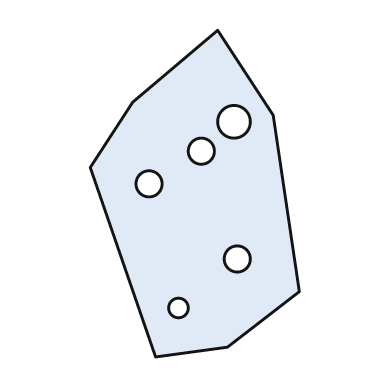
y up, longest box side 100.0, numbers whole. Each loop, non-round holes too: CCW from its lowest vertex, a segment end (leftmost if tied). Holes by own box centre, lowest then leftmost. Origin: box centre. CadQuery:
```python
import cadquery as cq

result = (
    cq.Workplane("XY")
    .moveTo(-12.0, -50.0)
    .lineTo(10.0, -47.0)
    .lineTo(32.0, -30.0)
    .lineTo(24.0, 24.0)
    .lineTo(7.0, 50.0)
    .lineTo(-19.0, 28.0)
    .lineTo(-32.0, 8.0)
    .close()
    .moveTo(-5.0, -35.0)
    .circle(3.0)
    .moveTo(13.0, -20.0)
    .circle(4.0)
    .moveTo(-14.0, 3.0)
    .circle(4.0)
    .moveTo(2.0, 13.0)
    .circle(4.0)
    .moveTo(12.0, 22.0)
    .circle(5.0)
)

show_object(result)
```